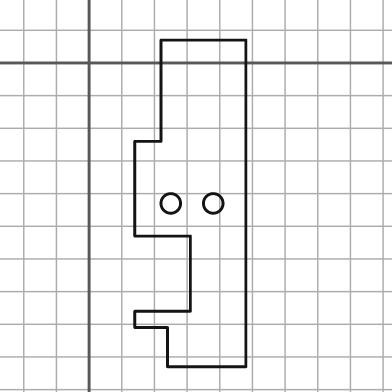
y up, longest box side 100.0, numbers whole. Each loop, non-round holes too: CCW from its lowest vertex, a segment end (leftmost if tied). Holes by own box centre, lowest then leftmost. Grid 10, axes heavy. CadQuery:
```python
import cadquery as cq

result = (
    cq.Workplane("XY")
    .moveTo(24.0, -93.0)
    .lineTo(48.0, -93.0)
    .lineTo(48.0, 7.0)
    .lineTo(22.0, 7.0)
    .lineTo(22.0, -24.0)
    .lineTo(14.0, -24.0)
    .lineTo(14.0, -53.0)
    .lineTo(31.0, -53.0)
    .lineTo(31.0, -76.0)
    .lineTo(14.0, -76.0)
    .lineTo(14.0, -81.0)
    .lineTo(24.0, -81.0)
    .close()
    .moveTo(25.0, -43.0)
    .circle(3.0)
    .moveTo(38.0, -43.0)
    .circle(3.0)
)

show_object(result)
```